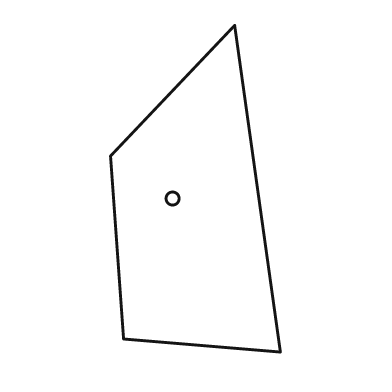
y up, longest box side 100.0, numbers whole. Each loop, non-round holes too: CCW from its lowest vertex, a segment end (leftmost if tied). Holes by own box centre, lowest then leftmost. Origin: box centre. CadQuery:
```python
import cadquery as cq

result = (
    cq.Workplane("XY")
    .moveTo(26.0, -50.0)
    .lineTo(12.0, 50.0)
    .lineTo(-26.0, 10.0)
    .lineTo(-22.0, -46.0)
    .close()
    .moveTo(-7.0, -3.0)
    .circle(2.0)
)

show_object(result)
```